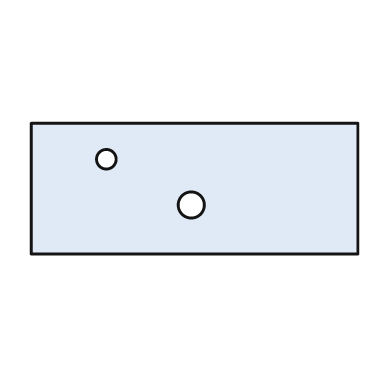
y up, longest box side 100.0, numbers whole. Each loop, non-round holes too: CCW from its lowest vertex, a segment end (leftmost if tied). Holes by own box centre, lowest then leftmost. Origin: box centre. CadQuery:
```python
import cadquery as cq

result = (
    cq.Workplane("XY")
    .moveTo(-50.0, -20.0)
    .lineTo(50.0, -20.0)
    .lineTo(50.0, 20.0)
    .lineTo(-50.0, 20.0)
    .close()
    .moveTo(-1.0, -5.0)
    .circle(4.0)
    .moveTo(-27.0, 9.0)
    .circle(3.0)
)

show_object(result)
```